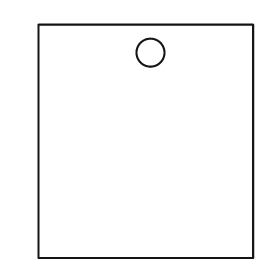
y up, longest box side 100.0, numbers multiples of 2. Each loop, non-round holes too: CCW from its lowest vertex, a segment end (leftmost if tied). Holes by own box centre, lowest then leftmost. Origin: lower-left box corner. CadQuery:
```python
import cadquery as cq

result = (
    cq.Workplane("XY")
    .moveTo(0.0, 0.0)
    .lineTo(92.0, 0.0)
    .lineTo(92.0, 100.0)
    .lineTo(0.0, 100.0)
    .close()
    .moveTo(48.0, 88.0)
    .circle(6.0)
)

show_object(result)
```